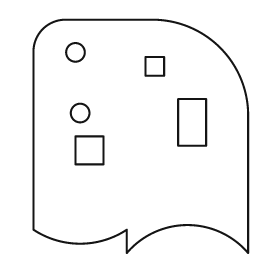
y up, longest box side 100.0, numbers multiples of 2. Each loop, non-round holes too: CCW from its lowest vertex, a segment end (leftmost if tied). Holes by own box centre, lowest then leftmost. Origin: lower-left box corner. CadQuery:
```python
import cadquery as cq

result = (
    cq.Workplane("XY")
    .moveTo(40.0, 0.0)
    .threePointArc((66.0, 12.0), (92.0, 0.0))
    .lineTo(92.0, 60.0)
    .threePointArc((80.0, 88.0), (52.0, 100.0))
    .lineTo(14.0, 100.0)
    .threePointArc((4.0, 96.0), (0.0, 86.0))
    .lineTo(0.0, 10.0)
    .threePointArc((20.0, 4.0), (40.0, 10.0))
    .close()
    .moveTo(18.0, 38.0)
    .lineTo(30.0, 38.0)
    .lineTo(30.0, 50.0)
    .lineTo(18.0, 50.0)
    .close()
    .moveTo(62.0, 46.0)
    .lineTo(74.0, 46.0)
    .lineTo(74.0, 66.0)
    .lineTo(62.0, 66.0)
    .close()
    .moveTo(20.0, 60.0)
    .circle(4.0)
    .moveTo(48.0, 76.0)
    .lineTo(56.0, 76.0)
    .lineTo(56.0, 84.0)
    .lineTo(48.0, 84.0)
    .close()
    .moveTo(18.0, 86.0)
    .circle(4.0)
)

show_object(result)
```